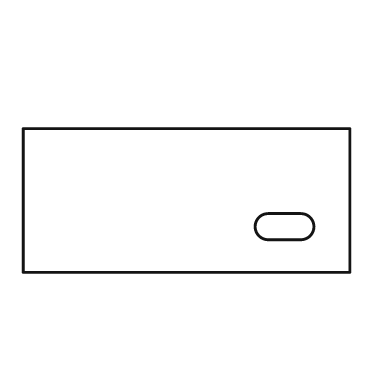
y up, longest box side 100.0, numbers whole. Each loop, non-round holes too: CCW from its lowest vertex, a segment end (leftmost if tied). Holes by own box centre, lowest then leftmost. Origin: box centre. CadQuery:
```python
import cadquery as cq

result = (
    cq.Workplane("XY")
    .moveTo(-50.0, -22.0)
    .lineTo(50.0, -22.0)
    .lineTo(50.0, 22.0)
    .lineTo(-50.0, 22.0)
    .close()
    .moveTo(25.0, -12.0)
    .lineTo(35.0, -12.0)
    .threePointArc((39.0, -8.0), (35.0, -4.0))
    .lineTo(25.0, -4.0)
    .threePointArc((21.0, -8.0), (25.0, -12.0))
    .close()
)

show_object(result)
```